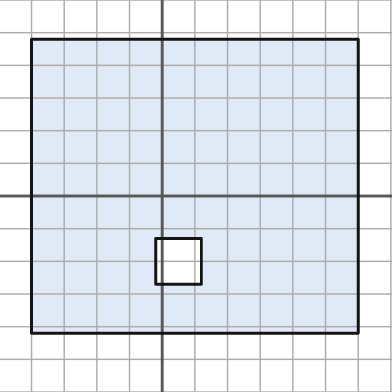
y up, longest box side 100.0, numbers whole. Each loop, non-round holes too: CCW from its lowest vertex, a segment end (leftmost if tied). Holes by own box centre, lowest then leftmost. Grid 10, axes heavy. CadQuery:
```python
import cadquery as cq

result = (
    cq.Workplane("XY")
    .moveTo(-40.0, -42.0)
    .lineTo(60.0, -42.0)
    .lineTo(60.0, 48.0)
    .lineTo(-40.0, 48.0)
    .close()
    .moveTo(-2.0, -27.0)
    .lineTo(12.0, -27.0)
    .lineTo(12.0, -13.0)
    .lineTo(-2.0, -13.0)
    .close()
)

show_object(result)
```